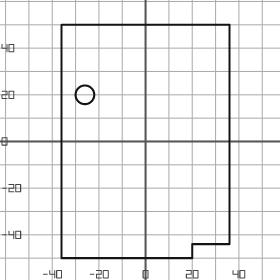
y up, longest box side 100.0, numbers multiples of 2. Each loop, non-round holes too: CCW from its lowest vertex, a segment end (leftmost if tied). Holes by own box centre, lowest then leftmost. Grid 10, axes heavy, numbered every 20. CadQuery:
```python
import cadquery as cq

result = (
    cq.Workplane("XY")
    .moveTo(-36.0, -50.0)
    .lineTo(20.0, -50.0)
    .lineTo(20.0, -44.0)
    .lineTo(36.0, -44.0)
    .lineTo(36.0, 50.0)
    .lineTo(-36.0, 50.0)
    .close()
    .moveTo(-26.0, 20.0)
    .circle(4.0)
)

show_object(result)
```